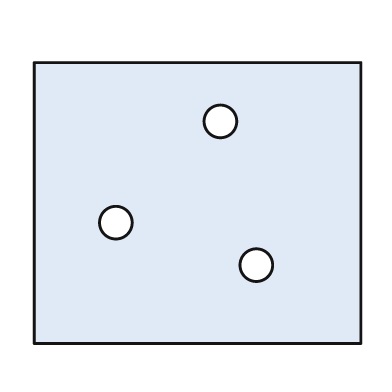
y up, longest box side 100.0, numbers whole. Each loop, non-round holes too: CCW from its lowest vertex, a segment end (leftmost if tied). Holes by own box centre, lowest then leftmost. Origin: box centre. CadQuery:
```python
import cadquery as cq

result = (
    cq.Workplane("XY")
    .moveTo(-50.0, -43.0)
    .lineTo(50.0, -43.0)
    .lineTo(50.0, 43.0)
    .lineTo(-50.0, 43.0)
    .close()
    .moveTo(18.0, -19.0)
    .circle(5.0)
    .moveTo(-25.0, -6.0)
    .circle(5.0)
    .moveTo(7.0, 25.0)
    .circle(5.0)
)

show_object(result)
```